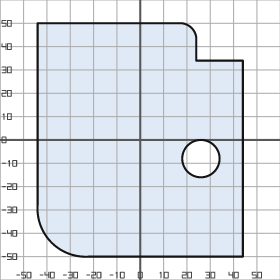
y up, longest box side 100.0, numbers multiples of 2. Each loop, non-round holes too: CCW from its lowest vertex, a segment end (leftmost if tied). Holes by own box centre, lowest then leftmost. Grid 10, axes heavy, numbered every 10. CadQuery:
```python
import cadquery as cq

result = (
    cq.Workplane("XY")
    .moveTo(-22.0, -50.0)
    .lineTo(44.0, -50.0)
    .lineTo(44.0, 34.0)
    .lineTo(24.0, 34.0)
    .lineTo(24.0, 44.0)
    .threePointArc((22.0, 48.0), (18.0, 50.0))
    .lineTo(-44.0, 50.0)
    .lineTo(-44.0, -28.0)
    .threePointArc((-38.0, -44.0), (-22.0, -50.0))
    .close()
    .moveTo(26.0, -8.0)
    .circle(8.0)
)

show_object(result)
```